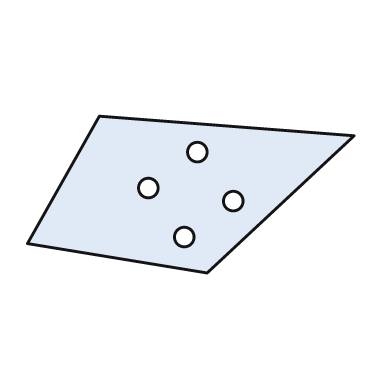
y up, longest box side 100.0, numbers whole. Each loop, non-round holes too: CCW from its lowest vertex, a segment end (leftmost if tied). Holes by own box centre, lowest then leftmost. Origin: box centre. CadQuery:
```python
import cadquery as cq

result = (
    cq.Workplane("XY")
    .moveTo(5.0, -24.0)
    .lineTo(50.0, 18.0)
    .lineTo(-28.0, 24.0)
    .lineTo(-50.0, -15.0)
    .close()
    .moveTo(-2.0, -13.0)
    .circle(3.0)
    .moveTo(13.0, -2.0)
    .circle(3.0)
    .moveTo(-13.0, 2.0)
    .circle(3.0)
    .moveTo(2.0, 13.0)
    .circle(3.0)
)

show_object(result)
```